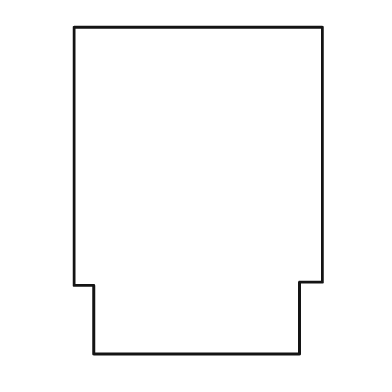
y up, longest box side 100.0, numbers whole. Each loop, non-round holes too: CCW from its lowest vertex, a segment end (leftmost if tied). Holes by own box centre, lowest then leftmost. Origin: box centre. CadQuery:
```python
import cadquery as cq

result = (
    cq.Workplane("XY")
    .moveTo(-32.0, -50.0)
    .lineTo(31.0, -50.0)
    .lineTo(31.0, -28.0)
    .lineTo(38.0, -28.0)
    .lineTo(38.0, 50.0)
    .lineTo(-38.0, 50.0)
    .lineTo(-38.0, -29.0)
    .lineTo(-32.0, -29.0)
    .close()
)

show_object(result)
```